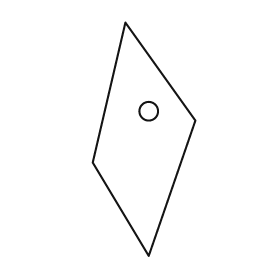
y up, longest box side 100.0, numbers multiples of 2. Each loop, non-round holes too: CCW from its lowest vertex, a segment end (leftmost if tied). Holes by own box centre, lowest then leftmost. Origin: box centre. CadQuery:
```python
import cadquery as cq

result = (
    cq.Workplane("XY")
    .moveTo(2.0, -50.0)
    .lineTo(22.0, 8.0)
    .lineTo(-8.0, 50.0)
    .lineTo(-22.0, -10.0)
    .close()
    .moveTo(2.0, 12.0)
    .circle(4.0)
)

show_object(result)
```